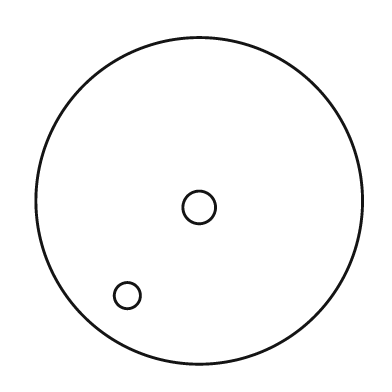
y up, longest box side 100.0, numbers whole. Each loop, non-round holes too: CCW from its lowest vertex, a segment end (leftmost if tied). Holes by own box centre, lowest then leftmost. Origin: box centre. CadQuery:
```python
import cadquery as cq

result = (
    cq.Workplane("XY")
    .moveTo(0.0, 0.0)
    .circle(50.0)
    .moveTo(-22.0, -29.0)
    .circle(4.0)
    .moveTo(0.0, -2.0)
    .circle(5.0)
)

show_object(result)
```